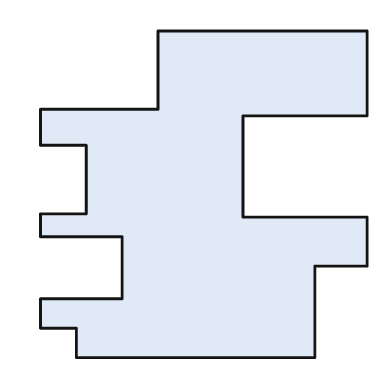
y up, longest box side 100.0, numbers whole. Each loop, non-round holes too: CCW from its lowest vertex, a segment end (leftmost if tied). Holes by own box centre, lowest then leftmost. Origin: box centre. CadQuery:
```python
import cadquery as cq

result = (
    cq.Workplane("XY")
    .moveTo(-39.0, -50.0)
    .lineTo(34.0, -50.0)
    .lineTo(34.0, -22.0)
    .lineTo(50.0, -22.0)
    .lineTo(50.0, -7.0)
    .lineTo(12.0, -7.0)
    .lineTo(12.0, 24.0)
    .lineTo(50.0, 24.0)
    .lineTo(50.0, 50.0)
    .lineTo(-14.0, 50.0)
    .lineTo(-14.0, 26.0)
    .lineTo(-50.0, 26.0)
    .lineTo(-50.0, 15.0)
    .lineTo(-36.0, 15.0)
    .lineTo(-36.0, -6.0)
    .lineTo(-50.0, -6.0)
    .lineTo(-50.0, -13.0)
    .lineTo(-25.0, -13.0)
    .lineTo(-25.0, -32.0)
    .lineTo(-50.0, -32.0)
    .lineTo(-50.0, -41.0)
    .lineTo(-39.0, -41.0)
    .close()
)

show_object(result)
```